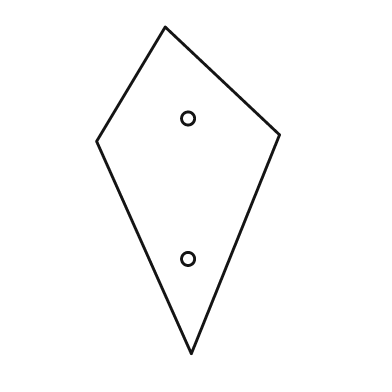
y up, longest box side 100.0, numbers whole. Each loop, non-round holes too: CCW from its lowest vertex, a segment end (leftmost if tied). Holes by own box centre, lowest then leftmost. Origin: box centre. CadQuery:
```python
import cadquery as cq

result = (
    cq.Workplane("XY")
    .moveTo(1.0, -50.0)
    .lineTo(28.0, 17.0)
    .lineTo(-7.0, 50.0)
    .lineTo(-28.0, 15.0)
    .close()
    .moveTo(0.0, -21.0)
    .circle(2.0)
    .moveTo(0.0, 22.0)
    .circle(2.0)
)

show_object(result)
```